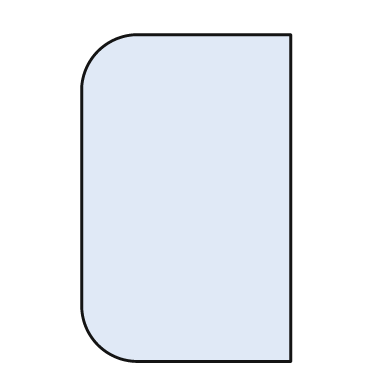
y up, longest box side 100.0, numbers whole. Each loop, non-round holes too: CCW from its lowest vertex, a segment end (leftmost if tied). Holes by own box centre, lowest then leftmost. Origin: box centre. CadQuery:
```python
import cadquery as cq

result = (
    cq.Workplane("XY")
    .moveTo(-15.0, -50.0)
    .lineTo(32.0, -50.0)
    .lineTo(32.0, 50.0)
    .lineTo(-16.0, 50.0)
    .threePointArc((-27.0, 45.0), (-32.0, 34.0))
    .lineTo(-32.0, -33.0)
    .threePointArc((-27.0, -45.0), (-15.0, -50.0))
    .close()
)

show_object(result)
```